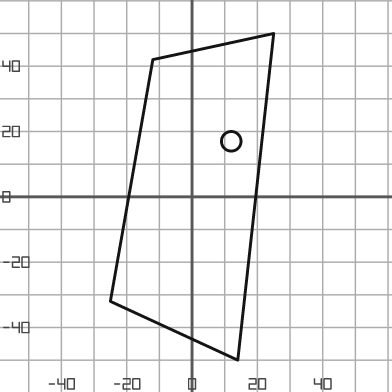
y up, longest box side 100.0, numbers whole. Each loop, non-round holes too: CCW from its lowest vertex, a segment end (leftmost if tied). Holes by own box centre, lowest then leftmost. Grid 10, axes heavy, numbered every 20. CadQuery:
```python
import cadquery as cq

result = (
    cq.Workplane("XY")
    .moveTo(14.0, -50.0)
    .lineTo(25.0, 50.0)
    .lineTo(-12.0, 42.0)
    .lineTo(-25.0, -32.0)
    .close()
    .moveTo(12.0, 17.0)
    .circle(3.0)
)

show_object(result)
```